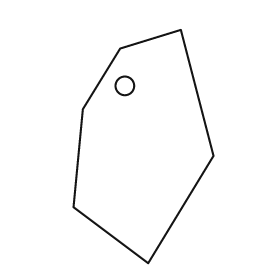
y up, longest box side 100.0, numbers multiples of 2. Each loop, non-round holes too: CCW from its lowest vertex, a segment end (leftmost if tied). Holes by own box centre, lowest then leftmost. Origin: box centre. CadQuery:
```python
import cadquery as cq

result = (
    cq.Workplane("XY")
    .moveTo(2.0, -50.0)
    .lineTo(30.0, -4.0)
    .lineTo(16.0, 50.0)
    .lineTo(-10.0, 42.0)
    .lineTo(-26.0, 16.0)
    .lineTo(-30.0, -26.0)
    .close()
    .moveTo(-8.0, 26.0)
    .circle(4.0)
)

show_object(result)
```